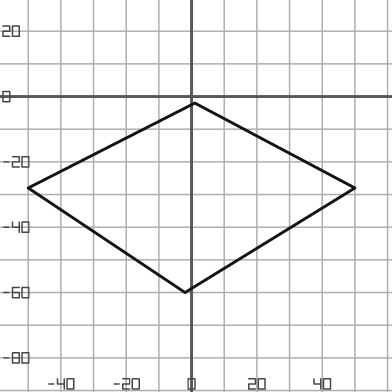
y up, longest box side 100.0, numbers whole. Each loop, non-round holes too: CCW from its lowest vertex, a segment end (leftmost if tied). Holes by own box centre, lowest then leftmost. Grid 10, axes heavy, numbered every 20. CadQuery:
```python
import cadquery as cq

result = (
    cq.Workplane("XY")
    .moveTo(-2.0, -60.0)
    .lineTo(50.0, -28.0)
    .lineTo(1.0, -2.0)
    .lineTo(-50.0, -28.0)
    .close()
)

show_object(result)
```